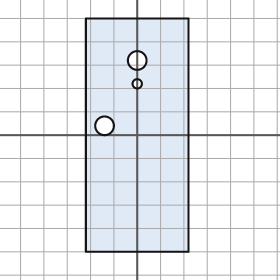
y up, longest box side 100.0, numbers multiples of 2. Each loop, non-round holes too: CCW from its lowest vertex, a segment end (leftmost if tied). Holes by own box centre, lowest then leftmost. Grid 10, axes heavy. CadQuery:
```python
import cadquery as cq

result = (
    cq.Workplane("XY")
    .moveTo(-22.0, -50.0)
    .lineTo(22.0, -50.0)
    .lineTo(22.0, 50.0)
    .lineTo(-22.0, 50.0)
    .close()
    .moveTo(-14.0, 4.0)
    .circle(4.0)
    .moveTo(0.0, 22.0)
    .circle(2.0)
    .moveTo(0.0, 32.0)
    .circle(4.0)
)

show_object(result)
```